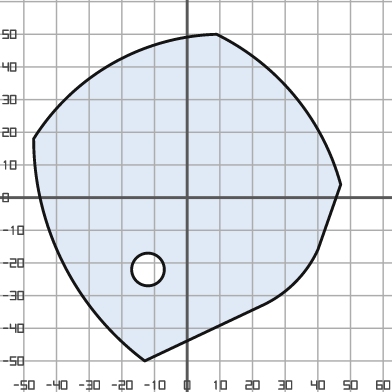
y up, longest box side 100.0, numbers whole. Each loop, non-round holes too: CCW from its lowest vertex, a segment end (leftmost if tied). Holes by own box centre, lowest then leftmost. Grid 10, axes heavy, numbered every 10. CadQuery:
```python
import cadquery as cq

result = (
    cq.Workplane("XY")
    .moveTo(-13.0, -50.0)
    .lineTo(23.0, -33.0)
    .threePointArc((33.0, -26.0), (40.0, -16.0))
    .lineTo(47.0, 4.0)
    .threePointArc((33.0, 31.0), (9.0, 50.0))
    .threePointArc((-23.0, 41.0), (-47.0, 18.0))
    .threePointArc((-38.0, -20.0), (-13.0, -50.0))
    .close()
    .moveTo(-12.0, -22.0)
    .circle(5.0)
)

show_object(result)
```